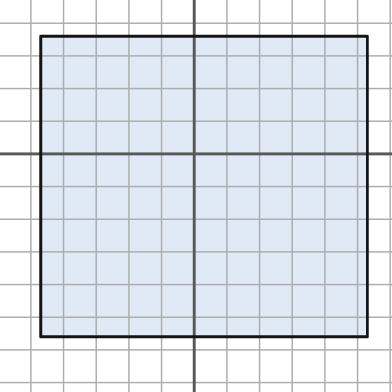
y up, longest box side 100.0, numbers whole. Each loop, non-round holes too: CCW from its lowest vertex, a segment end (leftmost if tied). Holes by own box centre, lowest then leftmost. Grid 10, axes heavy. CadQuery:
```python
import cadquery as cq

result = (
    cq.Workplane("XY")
    .moveTo(-47.0, -56.0)
    .lineTo(53.0, -56.0)
    .lineTo(53.0, 36.0)
    .lineTo(-47.0, 36.0)
    .close()
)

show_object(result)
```